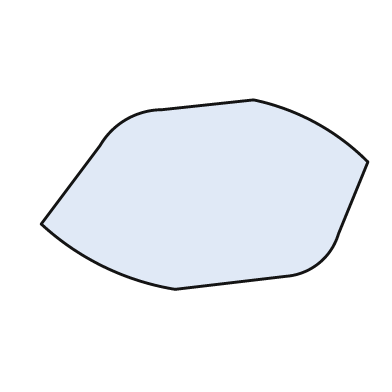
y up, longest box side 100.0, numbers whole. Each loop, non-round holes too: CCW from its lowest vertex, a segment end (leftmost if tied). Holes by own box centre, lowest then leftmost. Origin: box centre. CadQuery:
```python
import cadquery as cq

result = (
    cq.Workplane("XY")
    .moveTo(-9.0, -29.0)
    .lineTo(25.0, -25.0)
    .threePointArc((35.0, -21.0), (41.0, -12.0))
    .lineTo(50.0, 10.0)
    .threePointArc((34.0, 22.0), (15.0, 29.0))
    .lineTo(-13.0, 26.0)
    .threePointArc((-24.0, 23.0), (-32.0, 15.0))
    .lineTo(-50.0, -9.0)
    .threePointArc((-31.0, -22.0), (-9.0, -29.0))
    .close()
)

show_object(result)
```